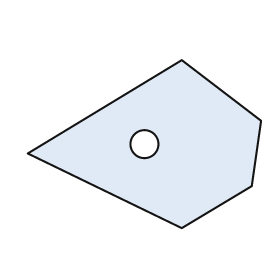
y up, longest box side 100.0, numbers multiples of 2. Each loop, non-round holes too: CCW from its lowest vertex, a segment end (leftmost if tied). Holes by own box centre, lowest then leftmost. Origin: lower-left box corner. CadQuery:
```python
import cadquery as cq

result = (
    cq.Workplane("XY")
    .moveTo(66.0, 0.0)
    .lineTo(96.0, 18.0)
    .lineTo(100.0, 46.0)
    .lineTo(66.0, 72.0)
    .lineTo(0.0, 32.0)
    .close()
    .moveTo(50.0, 36.0)
    .circle(6.0)
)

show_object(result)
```